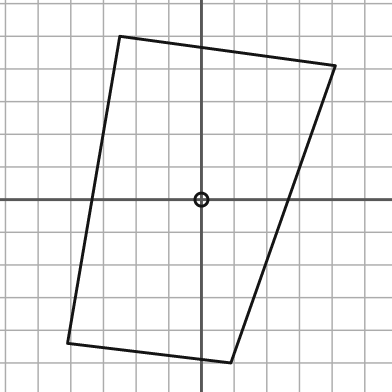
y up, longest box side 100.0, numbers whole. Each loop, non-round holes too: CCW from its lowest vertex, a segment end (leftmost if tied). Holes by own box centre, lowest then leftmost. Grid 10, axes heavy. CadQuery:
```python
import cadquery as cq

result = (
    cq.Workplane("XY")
    .moveTo(9.0, -50.0)
    .lineTo(41.0, 41.0)
    .lineTo(-25.0, 50.0)
    .lineTo(-41.0, -44.0)
    .close()
    .moveTo(0.0, 0.0)
    .circle(2.0)
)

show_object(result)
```